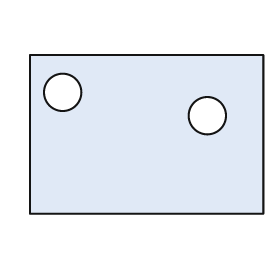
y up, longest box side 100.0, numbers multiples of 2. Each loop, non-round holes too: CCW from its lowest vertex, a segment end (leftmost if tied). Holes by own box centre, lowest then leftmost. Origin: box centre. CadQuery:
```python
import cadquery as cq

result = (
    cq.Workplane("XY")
    .moveTo(-50.0, -34.0)
    .lineTo(50.0, -34.0)
    .lineTo(50.0, 34.0)
    .lineTo(-50.0, 34.0)
    .close()
    .moveTo(26.0, 8.0)
    .circle(8.0)
    .moveTo(-36.0, 18.0)
    .circle(8.0)
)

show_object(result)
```